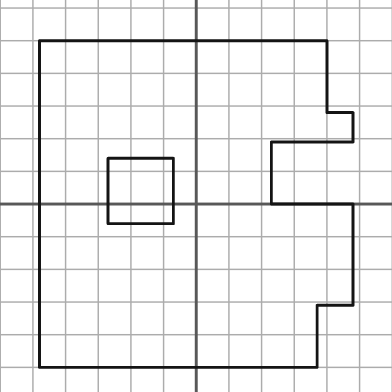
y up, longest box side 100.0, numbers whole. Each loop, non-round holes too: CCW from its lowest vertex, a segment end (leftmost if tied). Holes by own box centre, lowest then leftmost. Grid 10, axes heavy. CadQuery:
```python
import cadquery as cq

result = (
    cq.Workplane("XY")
    .moveTo(-48.0, -50.0)
    .lineTo(37.0, -50.0)
    .lineTo(37.0, -31.0)
    .lineTo(48.0, -31.0)
    .lineTo(48.0, 0.0)
    .lineTo(23.0, 0.0)
    .lineTo(23.0, 19.0)
    .lineTo(48.0, 19.0)
    .lineTo(48.0, 28.0)
    .lineTo(40.0, 28.0)
    .lineTo(40.0, 50.0)
    .lineTo(-48.0, 50.0)
    .close()
    .moveTo(-27.0, -6.0)
    .lineTo(-7.0, -6.0)
    .lineTo(-7.0, 14.0)
    .lineTo(-27.0, 14.0)
    .close()
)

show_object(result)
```